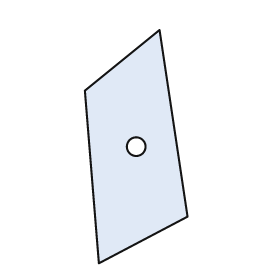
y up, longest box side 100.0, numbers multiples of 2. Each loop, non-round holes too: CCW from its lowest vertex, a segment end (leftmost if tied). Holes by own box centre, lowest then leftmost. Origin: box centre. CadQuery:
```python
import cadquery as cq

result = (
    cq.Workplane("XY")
    .moveTo(-16.0, -50.0)
    .lineTo(22.0, -30.0)
    .lineTo(10.0, 50.0)
    .lineTo(-22.0, 24.0)
    .close()
    .moveTo(0.0, 0.0)
    .circle(4.0)
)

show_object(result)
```